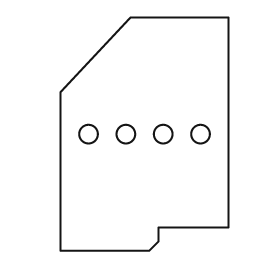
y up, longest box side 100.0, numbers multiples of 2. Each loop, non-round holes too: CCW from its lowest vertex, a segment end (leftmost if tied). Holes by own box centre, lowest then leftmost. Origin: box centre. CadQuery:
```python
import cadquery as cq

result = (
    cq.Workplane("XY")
    .moveTo(-36.0, -50.0)
    .lineTo(2.0, -50.0)
    .lineTo(6.0, -46.0)
    .lineTo(6.0, -40.0)
    .lineTo(36.0, -40.0)
    .lineTo(36.0, 50.0)
    .lineTo(-6.0, 50.0)
    .lineTo(-36.0, 18.0)
    .close()
    .moveTo(-24.0, 0.0)
    .circle(4.0)
    .moveTo(-8.0, 0.0)
    .circle(4.0)
    .moveTo(8.0, 0.0)
    .circle(4.0)
    .moveTo(24.0, 0.0)
    .circle(4.0)
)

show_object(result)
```